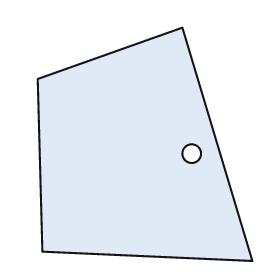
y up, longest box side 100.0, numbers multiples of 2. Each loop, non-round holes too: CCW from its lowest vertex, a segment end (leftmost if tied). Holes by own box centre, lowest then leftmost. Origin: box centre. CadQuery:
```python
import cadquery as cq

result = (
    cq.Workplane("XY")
    .moveTo(46.0, -50.0)
    .lineTo(16.0, 50.0)
    .lineTo(-46.0, 28.0)
    .lineTo(-44.0, -46.0)
    .close()
    .moveTo(20.0, -4.0)
    .circle(4.0)
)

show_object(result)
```